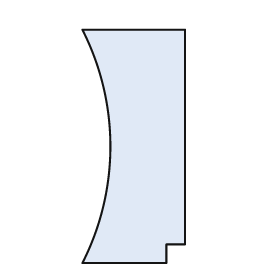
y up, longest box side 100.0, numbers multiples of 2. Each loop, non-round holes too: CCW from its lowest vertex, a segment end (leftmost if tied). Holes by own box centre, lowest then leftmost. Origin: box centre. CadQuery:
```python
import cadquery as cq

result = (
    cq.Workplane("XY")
    .moveTo(-22.0, -50.0)
    .lineTo(14.0, -50.0)
    .lineTo(14.0, -42.0)
    .lineTo(22.0, -42.0)
    .lineTo(22.0, 50.0)
    .lineTo(-22.0, 50.0)
    .threePointArc((-10.0, 0.0), (-22.0, -50.0))
    .close()
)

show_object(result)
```